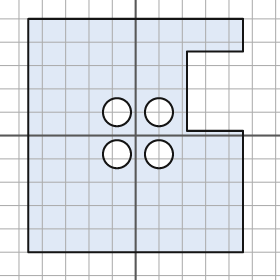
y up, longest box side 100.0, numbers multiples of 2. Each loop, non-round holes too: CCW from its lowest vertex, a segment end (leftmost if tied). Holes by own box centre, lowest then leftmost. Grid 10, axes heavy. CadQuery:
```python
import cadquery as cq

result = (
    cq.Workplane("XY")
    .moveTo(-46.0, -50.0)
    .lineTo(46.0, -50.0)
    .lineTo(46.0, 2.0)
    .lineTo(22.0, 2.0)
    .lineTo(22.0, 36.0)
    .lineTo(46.0, 36.0)
    .lineTo(46.0, 50.0)
    .lineTo(-46.0, 50.0)
    .close()
    .moveTo(-8.0, -8.0)
    .circle(6.0)
    .moveTo(10.0, -8.0)
    .circle(6.0)
    .moveTo(-8.0, 10.0)
    .circle(6.0)
    .moveTo(10.0, 10.0)
    .circle(6.0)
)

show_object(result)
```